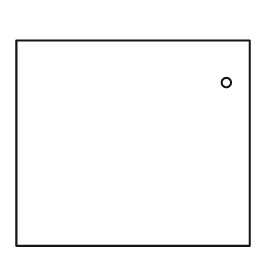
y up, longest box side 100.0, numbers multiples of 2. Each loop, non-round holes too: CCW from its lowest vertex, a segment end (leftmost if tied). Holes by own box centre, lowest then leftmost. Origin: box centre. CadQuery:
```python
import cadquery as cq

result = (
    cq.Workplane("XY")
    .moveTo(-50.0, -44.0)
    .lineTo(50.0, -44.0)
    .lineTo(50.0, 44.0)
    .lineTo(-50.0, 44.0)
    .close()
    .moveTo(40.0, 26.0)
    .circle(2.0)
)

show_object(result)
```